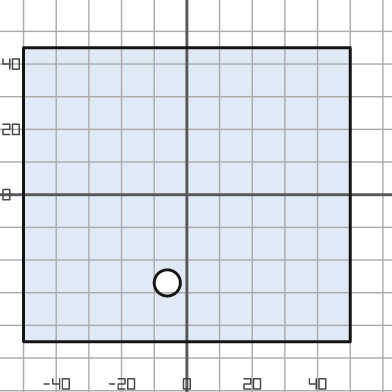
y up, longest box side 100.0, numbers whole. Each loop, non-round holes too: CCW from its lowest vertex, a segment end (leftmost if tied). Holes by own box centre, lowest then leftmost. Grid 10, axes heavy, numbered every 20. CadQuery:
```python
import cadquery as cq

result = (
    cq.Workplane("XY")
    .moveTo(-50.0, -45.0)
    .lineTo(50.0, -45.0)
    .lineTo(50.0, 45.0)
    .lineTo(-50.0, 45.0)
    .close()
    .moveTo(-6.0, -27.0)
    .circle(4.0)
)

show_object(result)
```